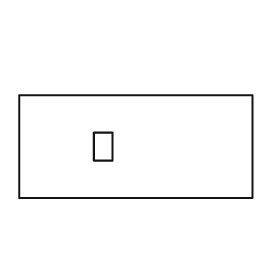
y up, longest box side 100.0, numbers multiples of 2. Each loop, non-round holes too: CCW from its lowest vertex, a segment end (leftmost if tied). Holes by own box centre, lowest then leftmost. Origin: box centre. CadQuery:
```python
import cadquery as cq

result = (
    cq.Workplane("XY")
    .moveTo(-50.0, -22.0)
    .lineTo(50.0, -22.0)
    .lineTo(50.0, 22.0)
    .lineTo(-50.0, 22.0)
    .close()
    .moveTo(-18.0, -6.0)
    .lineTo(-10.0, -6.0)
    .lineTo(-10.0, 6.0)
    .lineTo(-18.0, 6.0)
    .close()
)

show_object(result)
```